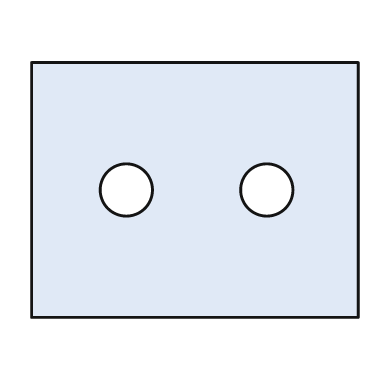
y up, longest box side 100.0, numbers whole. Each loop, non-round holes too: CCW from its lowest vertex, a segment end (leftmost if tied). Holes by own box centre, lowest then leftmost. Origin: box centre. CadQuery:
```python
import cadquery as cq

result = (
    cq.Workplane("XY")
    .moveTo(-50.0, -39.0)
    .lineTo(50.0, -39.0)
    .lineTo(50.0, 39.0)
    .lineTo(-50.0, 39.0)
    .close()
    .moveTo(-21.0, 0.0)
    .circle(8.0)
    .moveTo(22.0, 0.0)
    .circle(8.0)
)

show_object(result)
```